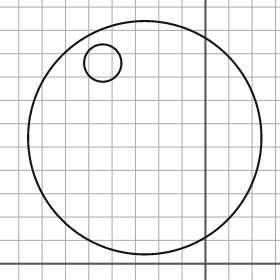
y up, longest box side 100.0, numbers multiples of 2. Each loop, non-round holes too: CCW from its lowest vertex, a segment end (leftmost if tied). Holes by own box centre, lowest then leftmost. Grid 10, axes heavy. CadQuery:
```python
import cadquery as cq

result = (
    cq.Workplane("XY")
    .moveTo(-26.0, 54.0)
    .circle(50.0)
    .moveTo(-44.0, 86.0)
    .circle(8.0)
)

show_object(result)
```